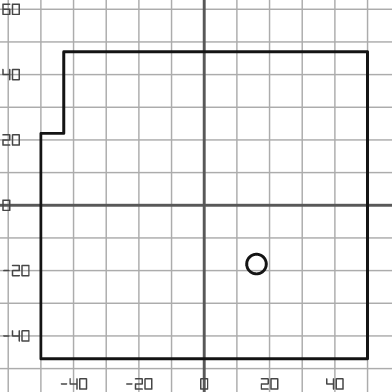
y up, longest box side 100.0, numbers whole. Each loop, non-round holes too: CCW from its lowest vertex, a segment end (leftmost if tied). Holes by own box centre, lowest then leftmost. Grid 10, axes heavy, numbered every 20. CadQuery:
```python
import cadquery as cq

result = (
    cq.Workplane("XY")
    .moveTo(-50.0, -47.0)
    .lineTo(50.0, -47.0)
    .lineTo(50.0, 47.0)
    .lineTo(-43.0, 47.0)
    .lineTo(-43.0, 22.0)
    .lineTo(-50.0, 22.0)
    .close()
    .moveTo(16.0, -18.0)
    .circle(3.0)
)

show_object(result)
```